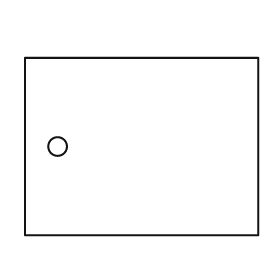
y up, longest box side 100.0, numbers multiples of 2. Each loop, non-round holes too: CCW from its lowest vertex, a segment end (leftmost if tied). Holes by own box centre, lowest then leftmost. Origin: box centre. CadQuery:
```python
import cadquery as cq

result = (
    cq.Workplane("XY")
    .moveTo(-50.0, -38.0)
    .lineTo(50.0, -38.0)
    .lineTo(50.0, 38.0)
    .lineTo(-50.0, 38.0)
    .close()
    .moveTo(-36.0, 0.0)
    .circle(4.0)
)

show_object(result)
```